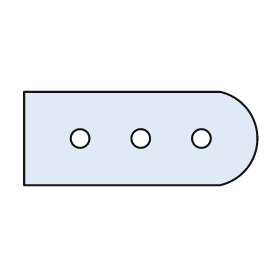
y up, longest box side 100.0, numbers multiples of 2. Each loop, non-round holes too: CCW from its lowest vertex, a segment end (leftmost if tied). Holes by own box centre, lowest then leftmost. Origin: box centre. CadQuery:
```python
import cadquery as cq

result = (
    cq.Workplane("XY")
    .moveTo(-50.0, -20.0)
    .lineTo(34.0, -20.0)
    .threePointArc((50.0, 0.0), (34.0, 20.0))
    .lineTo(-50.0, 20.0)
    .close()
    .moveTo(-26.0, 0.0)
    .circle(4.0)
    .moveTo(0.0, 0.0)
    .circle(4.0)
    .moveTo(26.0, 0.0)
    .circle(4.0)
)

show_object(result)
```